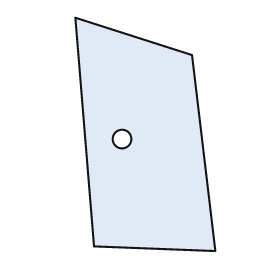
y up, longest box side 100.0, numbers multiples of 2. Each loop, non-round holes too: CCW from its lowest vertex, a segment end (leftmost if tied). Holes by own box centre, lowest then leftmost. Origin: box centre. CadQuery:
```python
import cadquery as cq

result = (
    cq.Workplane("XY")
    .moveTo(30.0, -50.0)
    .lineTo(20.0, 34.0)
    .lineTo(-30.0, 50.0)
    .lineTo(-22.0, -48.0)
    .close()
    .moveTo(-10.0, -2.0)
    .circle(4.0)
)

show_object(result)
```